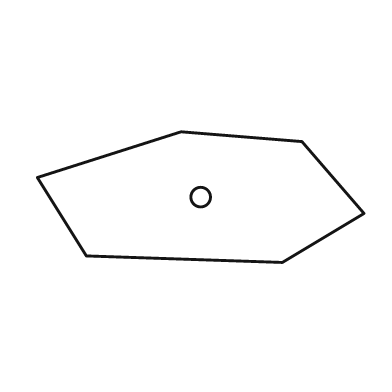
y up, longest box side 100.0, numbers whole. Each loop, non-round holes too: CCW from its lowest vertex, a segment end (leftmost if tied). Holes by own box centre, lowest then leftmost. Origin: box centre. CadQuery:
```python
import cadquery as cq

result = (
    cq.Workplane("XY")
    .moveTo(25.0, -20.0)
    .lineTo(50.0, -5.0)
    .lineTo(31.0, 17.0)
    .lineTo(-6.0, 20.0)
    .lineTo(-50.0, 6.0)
    .lineTo(-35.0, -18.0)
    .close()
    .moveTo(0.0, 0.0)
    .circle(3.0)
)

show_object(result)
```